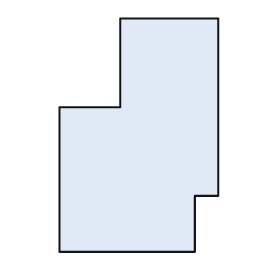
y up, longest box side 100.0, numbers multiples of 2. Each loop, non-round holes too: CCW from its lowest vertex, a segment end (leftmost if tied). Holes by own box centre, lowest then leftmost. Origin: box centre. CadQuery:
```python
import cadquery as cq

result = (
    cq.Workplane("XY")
    .moveTo(-34.0, -50.0)
    .lineTo(24.0, -50.0)
    .lineTo(24.0, -26.0)
    .lineTo(34.0, -26.0)
    .lineTo(34.0, 50.0)
    .lineTo(-8.0, 50.0)
    .lineTo(-8.0, 12.0)
    .lineTo(-34.0, 12.0)
    .close()
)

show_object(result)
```